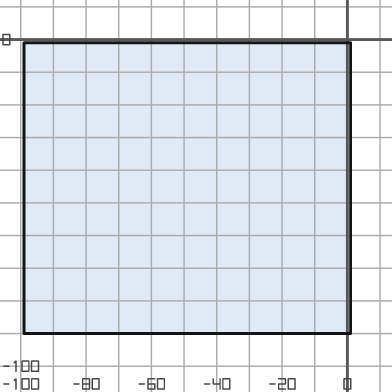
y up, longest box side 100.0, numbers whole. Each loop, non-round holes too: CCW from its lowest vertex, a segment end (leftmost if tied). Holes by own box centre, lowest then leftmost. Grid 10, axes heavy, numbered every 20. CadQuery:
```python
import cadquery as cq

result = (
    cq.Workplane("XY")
    .moveTo(-99.0, -90.0)
    .lineTo(1.0, -90.0)
    .lineTo(1.0, -1.0)
    .lineTo(-99.0, -1.0)
    .close()
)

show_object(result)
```